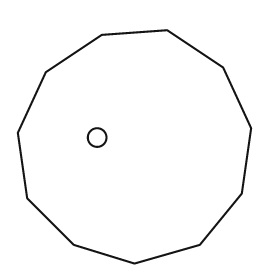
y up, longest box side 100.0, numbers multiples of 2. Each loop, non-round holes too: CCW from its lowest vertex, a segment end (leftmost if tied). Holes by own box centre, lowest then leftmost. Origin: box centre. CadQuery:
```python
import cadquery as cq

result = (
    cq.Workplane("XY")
    .moveTo(0.0, -50.0)
    .lineTo(28.0, -42.0)
    .lineTo(46.0, -20.0)
    .lineTo(50.0, 8.0)
    .lineTo(38.0, 34.0)
    .lineTo(14.0, 50.0)
    .lineTo(-14.0, 48.0)
    .lineTo(-38.0, 32.0)
    .lineTo(-50.0, 6.0)
    .lineTo(-46.0, -22.0)
    .lineTo(-26.0, -42.0)
    .close()
    .moveTo(-16.0, 4.0)
    .circle(4.0)
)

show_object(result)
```